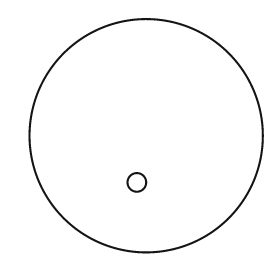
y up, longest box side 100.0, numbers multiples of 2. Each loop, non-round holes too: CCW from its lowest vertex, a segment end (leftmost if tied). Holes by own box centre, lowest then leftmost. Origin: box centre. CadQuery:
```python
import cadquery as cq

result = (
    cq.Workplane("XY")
    .moveTo(0.0, 0.0)
    .circle(50.0)
    .moveTo(-4.0, -20.0)
    .circle(4.0)
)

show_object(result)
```